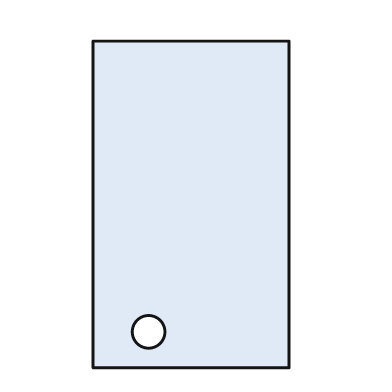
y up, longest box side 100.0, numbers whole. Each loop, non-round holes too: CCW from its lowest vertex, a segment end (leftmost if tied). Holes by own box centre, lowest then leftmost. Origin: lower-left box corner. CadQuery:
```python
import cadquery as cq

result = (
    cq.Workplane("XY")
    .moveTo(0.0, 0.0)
    .lineTo(60.0, 0.0)
    .lineTo(60.0, 100.0)
    .lineTo(0.0, 100.0)
    .close()
    .moveTo(17.0, 11.0)
    .circle(5.0)
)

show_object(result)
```